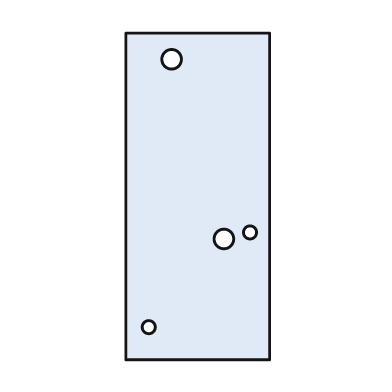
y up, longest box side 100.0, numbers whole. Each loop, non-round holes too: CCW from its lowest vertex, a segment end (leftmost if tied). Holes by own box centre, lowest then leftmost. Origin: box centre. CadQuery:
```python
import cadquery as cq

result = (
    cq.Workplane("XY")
    .moveTo(-22.0, -50.0)
    .lineTo(22.0, -50.0)
    .lineTo(22.0, 50.0)
    .lineTo(-22.0, 50.0)
    .close()
    .moveTo(-15.0, -40.0)
    .circle(2.0)
    .moveTo(8.0, -13.0)
    .circle(3.0)
    .moveTo(16.0, -11.0)
    .circle(2.0)
    .moveTo(-8.0, 42.0)
    .circle(3.0)
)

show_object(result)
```